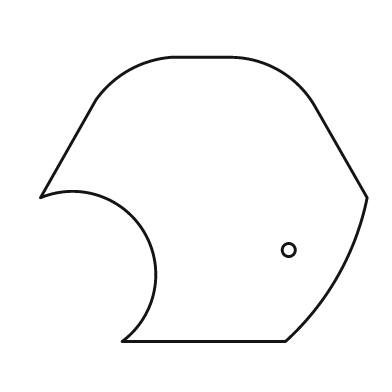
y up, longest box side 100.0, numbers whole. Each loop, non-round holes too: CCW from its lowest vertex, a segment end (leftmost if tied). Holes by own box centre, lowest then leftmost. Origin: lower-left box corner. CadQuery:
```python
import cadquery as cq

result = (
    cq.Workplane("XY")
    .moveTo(25.0, 0.0)
    .lineTo(75.0, 0.0)
    .threePointArc((91.0, 20.0), (100.0, 44.0))
    .lineTo(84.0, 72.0)
    .threePointArc((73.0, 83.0), (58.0, 87.0))
    .lineTo(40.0, 87.0)
    .threePointArc((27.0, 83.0), (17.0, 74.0))
    .lineTo(0.0, 44.0)
    .threePointArc((32.0, 33.0), (25.0, 0.0))
    .close()
    .moveTo(76.0, 28.0)
    .circle(2.0)
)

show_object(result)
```